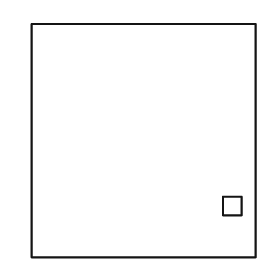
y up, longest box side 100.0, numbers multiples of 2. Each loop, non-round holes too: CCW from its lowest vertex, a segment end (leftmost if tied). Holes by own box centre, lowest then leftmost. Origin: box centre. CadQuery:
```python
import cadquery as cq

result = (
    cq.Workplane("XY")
    .moveTo(-48.0, -50.0)
    .lineTo(48.0, -50.0)
    .lineTo(48.0, 50.0)
    .lineTo(-48.0, 50.0)
    .close()
    .moveTo(34.0, -32.0)
    .lineTo(42.0, -32.0)
    .lineTo(42.0, -24.0)
    .lineTo(34.0, -24.0)
    .close()
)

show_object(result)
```